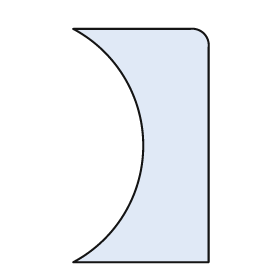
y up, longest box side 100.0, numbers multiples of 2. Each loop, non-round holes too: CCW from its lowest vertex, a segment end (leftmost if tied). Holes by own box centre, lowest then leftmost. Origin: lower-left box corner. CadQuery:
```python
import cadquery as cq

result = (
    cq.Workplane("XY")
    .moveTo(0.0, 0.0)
    .lineTo(58.0, 0.0)
    .lineTo(58.0, 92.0)
    .threePointArc((56.0, 98.0), (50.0, 100.0))
    .lineTo(0.0, 100.0)
    .threePointArc((30.0, 50.0), (0.0, 0.0))
    .close()
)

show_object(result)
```